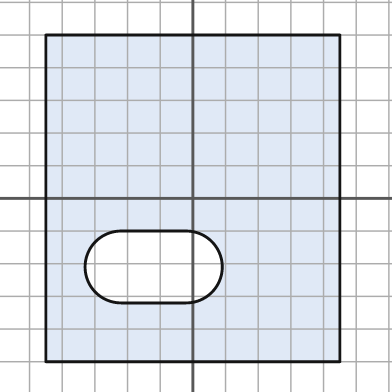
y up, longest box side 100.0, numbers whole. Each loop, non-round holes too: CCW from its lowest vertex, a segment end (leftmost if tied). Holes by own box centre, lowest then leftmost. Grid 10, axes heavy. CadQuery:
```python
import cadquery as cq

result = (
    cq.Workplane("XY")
    .moveTo(-45.0, -50.0)
    .lineTo(45.0, -50.0)
    .lineTo(45.0, 50.0)
    .lineTo(-45.0, 50.0)
    .close()
    .moveTo(-22.0, -32.0)
    .lineTo(-2.0, -32.0)
    .threePointArc((9.0, -21.0), (-2.0, -10.0))
    .lineTo(-22.0, -10.0)
    .threePointArc((-33.0, -21.0), (-22.0, -32.0))
    .close()
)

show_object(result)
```